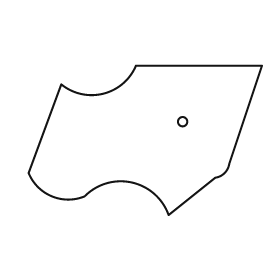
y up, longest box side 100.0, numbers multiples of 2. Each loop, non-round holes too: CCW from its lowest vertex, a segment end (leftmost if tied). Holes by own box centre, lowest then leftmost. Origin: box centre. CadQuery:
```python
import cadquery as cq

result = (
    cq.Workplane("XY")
    .moveTo(10.0, -32.0)
    .lineTo(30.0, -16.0)
    .threePointArc((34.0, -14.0), (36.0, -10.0))
    .lineTo(50.0, 32.0)
    .lineTo(-4.0, 32.0)
    .threePointArc((-18.0, 20.0), (-36.0, 24.0))
    .lineTo(-50.0, -14.0)
    .threePointArc((-40.0, -24.0), (-26.0, -24.0))
    .threePointArc((-6.0, -18.0), (10.0, -32.0))
    .close()
    .moveTo(16.0, 8.0)
    .circle(2.0)
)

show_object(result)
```